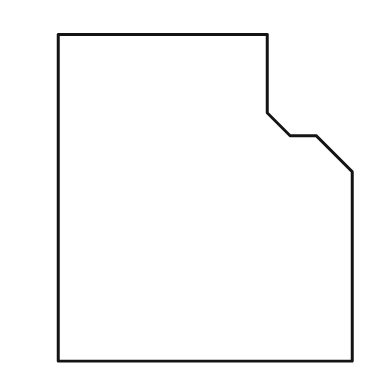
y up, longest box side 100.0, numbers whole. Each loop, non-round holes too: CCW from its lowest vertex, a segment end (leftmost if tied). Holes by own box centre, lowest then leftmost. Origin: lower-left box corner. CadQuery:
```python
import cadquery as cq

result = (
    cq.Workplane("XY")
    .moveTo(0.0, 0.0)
    .lineTo(90.0, 0.0)
    .lineTo(90.0, 58.0)
    .lineTo(79.0, 69.0)
    .lineTo(71.0, 69.0)
    .lineTo(64.0, 76.0)
    .lineTo(64.0, 100.0)
    .lineTo(0.0, 100.0)
    .close()
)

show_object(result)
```